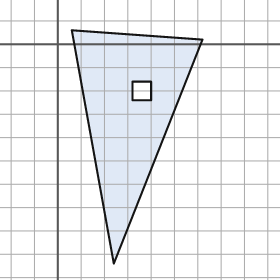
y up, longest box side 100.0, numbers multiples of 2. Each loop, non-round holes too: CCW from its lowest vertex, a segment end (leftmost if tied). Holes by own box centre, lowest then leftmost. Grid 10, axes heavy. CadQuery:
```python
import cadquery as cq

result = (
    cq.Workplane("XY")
    .moveTo(24.0, -94.0)
    .lineTo(62.0, 2.0)
    .lineTo(6.0, 6.0)
    .close()
    .moveTo(32.0, -24.0)
    .lineTo(40.0, -24.0)
    .lineTo(40.0, -16.0)
    .lineTo(32.0, -16.0)
    .close()
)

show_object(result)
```